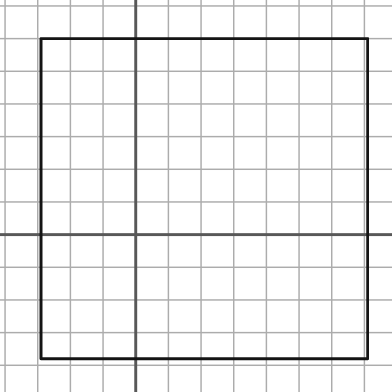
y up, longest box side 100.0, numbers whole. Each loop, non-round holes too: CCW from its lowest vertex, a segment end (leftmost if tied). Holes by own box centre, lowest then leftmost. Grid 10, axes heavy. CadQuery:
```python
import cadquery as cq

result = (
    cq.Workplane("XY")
    .moveTo(-29.0, -38.0)
    .lineTo(71.0, -38.0)
    .lineTo(71.0, 60.0)
    .lineTo(-29.0, 60.0)
    .close()
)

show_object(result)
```